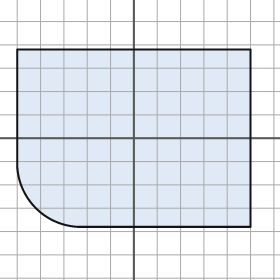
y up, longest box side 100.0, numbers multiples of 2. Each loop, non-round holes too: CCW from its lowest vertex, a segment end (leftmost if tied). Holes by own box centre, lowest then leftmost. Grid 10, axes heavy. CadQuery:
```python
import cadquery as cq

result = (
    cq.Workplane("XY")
    .moveTo(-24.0, -38.0)
    .lineTo(50.0, -38.0)
    .lineTo(50.0, 38.0)
    .lineTo(-50.0, 38.0)
    .lineTo(-50.0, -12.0)
    .threePointArc((-42.0, -30.0), (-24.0, -38.0))
    .close()
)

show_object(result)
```